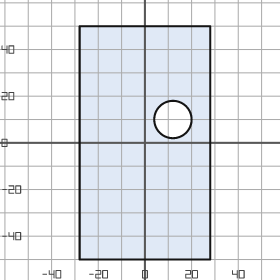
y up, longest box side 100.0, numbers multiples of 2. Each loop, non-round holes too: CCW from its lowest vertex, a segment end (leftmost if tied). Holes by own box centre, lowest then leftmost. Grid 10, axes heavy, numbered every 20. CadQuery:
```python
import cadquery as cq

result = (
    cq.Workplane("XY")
    .moveTo(-28.0, -50.0)
    .lineTo(28.0, -50.0)
    .lineTo(28.0, 50.0)
    .lineTo(-28.0, 50.0)
    .close()
    .moveTo(12.0, 10.0)
    .circle(8.0)
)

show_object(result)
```